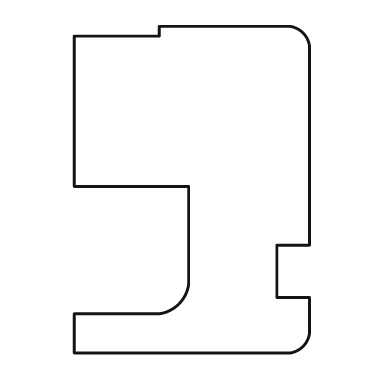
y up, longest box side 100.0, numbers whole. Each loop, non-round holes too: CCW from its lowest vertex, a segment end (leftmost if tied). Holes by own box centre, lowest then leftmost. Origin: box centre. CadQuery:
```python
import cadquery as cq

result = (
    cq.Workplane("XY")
    .moveTo(-36.0, -50.0)
    .lineTo(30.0, -50.0)
    .threePointArc((34.0, -48.0), (36.0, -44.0))
    .lineTo(36.0, -33.0)
    .lineTo(26.0, -33.0)
    .lineTo(26.0, -17.0)
    .lineTo(36.0, -17.0)
    .lineTo(36.0, 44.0)
    .threePointArc((34.0, 48.0), (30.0, 50.0))
    .lineTo(-10.0, 50.0)
    .lineTo(-10.0, 47.0)
    .lineTo(-36.0, 47.0)
    .lineTo(-36.0, 1.0)
    .lineTo(-1.0, 1.0)
    .lineTo(-1.0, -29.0)
    .threePointArc((-4.0, -35.0), (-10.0, -38.0))
    .lineTo(-36.0, -38.0)
    .close()
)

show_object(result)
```